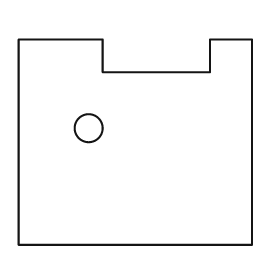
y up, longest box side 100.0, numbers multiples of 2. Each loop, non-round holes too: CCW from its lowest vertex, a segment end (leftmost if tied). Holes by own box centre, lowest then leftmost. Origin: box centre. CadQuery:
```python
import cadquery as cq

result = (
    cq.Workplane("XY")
    .moveTo(-50.0, -44.0)
    .lineTo(50.0, -44.0)
    .lineTo(50.0, 44.0)
    .lineTo(32.0, 44.0)
    .lineTo(32.0, 30.0)
    .lineTo(-14.0, 30.0)
    .lineTo(-14.0, 44.0)
    .lineTo(-50.0, 44.0)
    .close()
    .moveTo(-20.0, 6.0)
    .circle(6.0)
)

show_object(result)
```